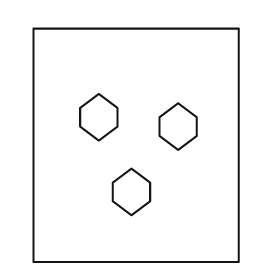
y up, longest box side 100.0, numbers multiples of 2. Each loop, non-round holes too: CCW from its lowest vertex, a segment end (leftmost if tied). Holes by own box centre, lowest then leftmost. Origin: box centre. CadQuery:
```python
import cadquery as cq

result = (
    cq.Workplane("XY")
    .moveTo(-44.0, -50.0)
    .lineTo(44.0, -50.0)
    .lineTo(44.0, 50.0)
    .lineTo(-44.0, 50.0)
    .close()
    .moveTo(-2.0, -30.0)
    .lineTo(6.0, -24.0)
    .lineTo(6.0, -16.0)
    .lineTo(-2.0, -10.0)
    .lineTo(-10.0, -16.0)
    .lineTo(-10.0, -24.0)
    .close()
    .moveTo(18.0, -2.0)
    .lineTo(26.0, 4.0)
    .lineTo(26.0, 12.0)
    .lineTo(18.0, 18.0)
    .lineTo(10.0, 12.0)
    .lineTo(10.0, 4.0)
    .close()
    .moveTo(-16.0, 2.0)
    .lineTo(-8.0, 8.0)
    .lineTo(-8.0, 16.0)
    .lineTo(-16.0, 22.0)
    .lineTo(-24.0, 16.0)
    .lineTo(-24.0, 8.0)
    .close()
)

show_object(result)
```